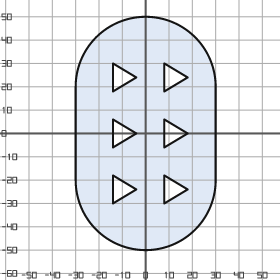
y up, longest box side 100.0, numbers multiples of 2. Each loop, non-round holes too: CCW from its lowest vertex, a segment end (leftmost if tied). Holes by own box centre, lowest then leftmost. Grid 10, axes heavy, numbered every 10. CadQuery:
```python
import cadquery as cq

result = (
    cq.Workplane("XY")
    .moveTo(-30.0, -20.0)
    .threePointArc((0.0, -50.0), (30.0, -20.0))
    .lineTo(30.0, 20.0)
    .threePointArc((0.0, 50.0), (-30.0, 20.0))
    .close()
    .moveTo(-14.0, -30.0)
    .lineTo(-4.0, -24.0)
    .lineTo(-14.0, -18.0)
    .close()
    .moveTo(8.0, -30.0)
    .lineTo(18.0, -24.0)
    .lineTo(8.0, -18.0)
    .close()
    .moveTo(-14.0, -6.0)
    .lineTo(-4.0, 0.0)
    .lineTo(-14.0, 6.0)
    .close()
    .moveTo(8.0, -6.0)
    .lineTo(18.0, 0.0)
    .lineTo(8.0, 6.0)
    .close()
    .moveTo(-14.0, 18.0)
    .lineTo(-4.0, 24.0)
    .lineTo(-14.0, 30.0)
    .close()
    .moveTo(8.0, 18.0)
    .lineTo(18.0, 24.0)
    .lineTo(8.0, 30.0)
    .close()
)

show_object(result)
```